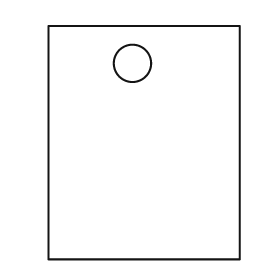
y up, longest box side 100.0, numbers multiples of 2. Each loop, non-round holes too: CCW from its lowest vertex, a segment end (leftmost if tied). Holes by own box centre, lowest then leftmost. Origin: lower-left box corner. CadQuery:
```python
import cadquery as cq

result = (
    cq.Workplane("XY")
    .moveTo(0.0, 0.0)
    .lineTo(82.0, 0.0)
    .lineTo(82.0, 100.0)
    .lineTo(0.0, 100.0)
    .close()
    .moveTo(36.0, 84.0)
    .circle(8.0)
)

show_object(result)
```